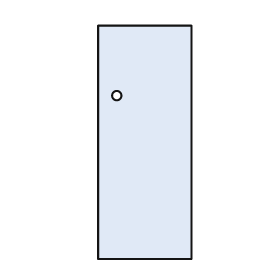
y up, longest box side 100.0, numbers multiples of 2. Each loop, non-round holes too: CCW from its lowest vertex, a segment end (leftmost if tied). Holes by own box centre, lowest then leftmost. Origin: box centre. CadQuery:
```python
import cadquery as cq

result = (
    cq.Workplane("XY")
    .moveTo(-20.0, -50.0)
    .lineTo(20.0, -50.0)
    .lineTo(20.0, 50.0)
    .lineTo(-20.0, 50.0)
    .close()
    .moveTo(-12.0, 20.0)
    .circle(2.0)
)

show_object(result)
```